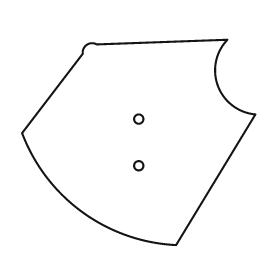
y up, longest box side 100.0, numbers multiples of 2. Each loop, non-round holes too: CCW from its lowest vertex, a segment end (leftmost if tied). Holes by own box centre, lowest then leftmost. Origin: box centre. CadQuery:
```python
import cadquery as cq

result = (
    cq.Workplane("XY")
    .moveTo(16.0, -44.0)
    .lineTo(50.0, 12.0)
    .threePointArc((34.0, 24.0), (38.0, 44.0))
    .lineTo(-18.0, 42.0)
    .threePointArc((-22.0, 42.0), (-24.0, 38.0))
    .lineTo(-50.0, 4.0)
    .threePointArc((-24.0, -30.0), (16.0, -44.0))
    .close()
    .moveTo(0.0, -10.0)
    .circle(2.0)
    .moveTo(0.0, 10.0)
    .circle(2.0)
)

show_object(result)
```